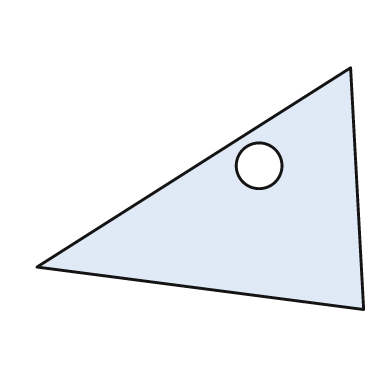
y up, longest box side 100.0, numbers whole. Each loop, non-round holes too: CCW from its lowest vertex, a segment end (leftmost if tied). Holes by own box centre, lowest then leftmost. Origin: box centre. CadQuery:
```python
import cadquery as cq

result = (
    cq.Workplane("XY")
    .moveTo(50.0, -37.0)
    .lineTo(46.0, 37.0)
    .lineTo(-50.0, -24.0)
    .close()
    .moveTo(18.0, 7.0)
    .circle(7.0)
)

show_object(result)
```